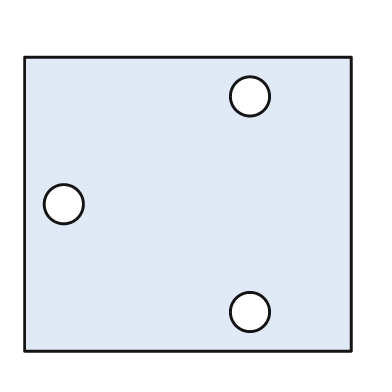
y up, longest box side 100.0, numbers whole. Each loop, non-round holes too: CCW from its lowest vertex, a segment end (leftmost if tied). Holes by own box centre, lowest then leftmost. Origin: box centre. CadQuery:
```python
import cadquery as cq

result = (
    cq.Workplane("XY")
    .moveTo(-50.0, -45.0)
    .lineTo(50.0, -45.0)
    .lineTo(50.0, 45.0)
    .lineTo(-50.0, 45.0)
    .close()
    .moveTo(19.0, -33.0)
    .circle(6.0)
    .moveTo(-38.0, 0.0)
    .circle(6.0)
    .moveTo(19.0, 33.0)
    .circle(6.0)
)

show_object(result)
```